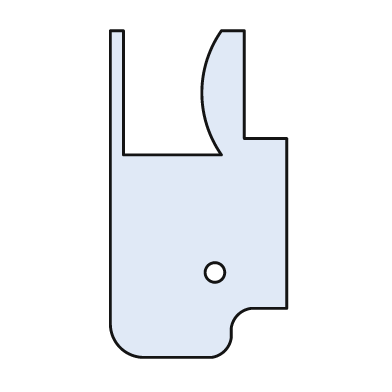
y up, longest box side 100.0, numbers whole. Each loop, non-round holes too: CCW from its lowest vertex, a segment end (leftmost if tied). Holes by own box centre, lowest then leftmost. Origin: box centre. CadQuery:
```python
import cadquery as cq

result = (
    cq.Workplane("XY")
    .moveTo(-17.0, -50.0)
    .lineTo(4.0, -50.0)
    .threePointArc((8.0, -48.0), (10.0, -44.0))
    .lineTo(10.0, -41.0)
    .threePointArc((12.0, -37.0), (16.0, -35.0))
    .lineTo(27.0, -35.0)
    .lineTo(27.0, 17.0)
    .lineTo(14.0, 17.0)
    .lineTo(14.0, 50.0)
    .lineTo(7.0, 50.0)
    .threePointArc((1.0, 31.0), (7.0, 12.0))
    .lineTo(-23.0, 12.0)
    .lineTo(-23.0, 50.0)
    .lineTo(-27.0, 50.0)
    .lineTo(-27.0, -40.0)
    .threePointArc((-24.0, -47.0), (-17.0, -50.0))
    .close()
    .moveTo(5.0, -24.0)
    .circle(3.0)
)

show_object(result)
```